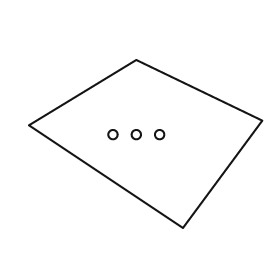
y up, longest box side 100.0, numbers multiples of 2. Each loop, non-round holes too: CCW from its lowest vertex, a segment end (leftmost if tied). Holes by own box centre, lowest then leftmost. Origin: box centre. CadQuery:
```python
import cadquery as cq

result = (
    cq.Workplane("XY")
    .moveTo(16.0, -36.0)
    .lineTo(50.0, 10.0)
    .lineTo(-4.0, 36.0)
    .lineTo(-50.0, 8.0)
    .close()
    .moveTo(-14.0, 4.0)
    .circle(2.0)
    .moveTo(-4.0, 4.0)
    .circle(2.0)
    .moveTo(6.0, 4.0)
    .circle(2.0)
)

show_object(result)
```